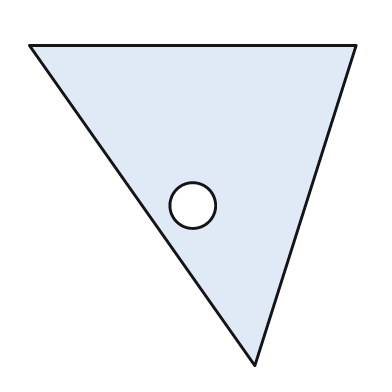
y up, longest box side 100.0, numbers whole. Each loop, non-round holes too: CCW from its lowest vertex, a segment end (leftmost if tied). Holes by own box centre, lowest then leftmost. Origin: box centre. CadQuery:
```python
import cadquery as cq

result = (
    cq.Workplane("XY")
    .moveTo(19.0, -49.0)
    .lineTo(50.0, 49.0)
    .lineTo(-50.0, 49.0)
    .close()
    .moveTo(0.0, 0.0)
    .circle(7.0)
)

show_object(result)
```